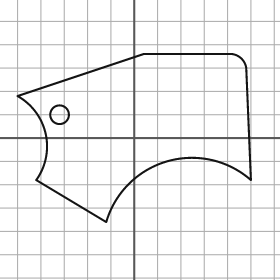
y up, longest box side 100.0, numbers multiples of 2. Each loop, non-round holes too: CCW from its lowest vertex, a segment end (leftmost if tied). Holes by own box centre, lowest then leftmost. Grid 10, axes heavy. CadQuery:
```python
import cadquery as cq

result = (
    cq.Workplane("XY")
    .moveTo(-12.0, -36.0)
    .threePointArc((14.0, -10.0), (50.0, -18.0))
    .lineTo(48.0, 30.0)
    .threePointArc((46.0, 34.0), (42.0, 36.0))
    .lineTo(4.0, 36.0)
    .lineTo(-50.0, 18.0)
    .threePointArc((-38.0, 2.0), (-42.0, -18.0))
    .close()
    .moveTo(-32.0, 10.0)
    .circle(4.0)
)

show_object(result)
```